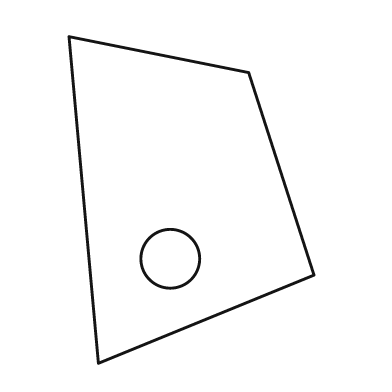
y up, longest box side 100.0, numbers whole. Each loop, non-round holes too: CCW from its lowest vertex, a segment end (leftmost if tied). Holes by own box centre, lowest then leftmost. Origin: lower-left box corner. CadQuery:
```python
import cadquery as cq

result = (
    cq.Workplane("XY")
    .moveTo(9.0, 0.0)
    .lineTo(75.0, 27.0)
    .lineTo(55.0, 89.0)
    .lineTo(0.0, 100.0)
    .close()
    .moveTo(31.0, 32.0)
    .circle(9.0)
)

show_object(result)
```